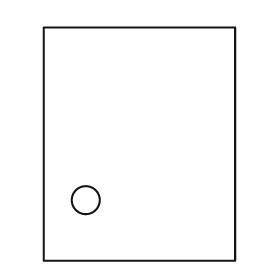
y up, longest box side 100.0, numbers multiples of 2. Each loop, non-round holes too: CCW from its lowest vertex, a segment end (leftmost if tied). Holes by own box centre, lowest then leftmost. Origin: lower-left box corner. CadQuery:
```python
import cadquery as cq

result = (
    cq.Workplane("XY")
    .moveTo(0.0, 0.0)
    .lineTo(82.0, 0.0)
    .lineTo(82.0, 100.0)
    .lineTo(0.0, 100.0)
    .close()
    .moveTo(18.0, 26.0)
    .circle(6.0)
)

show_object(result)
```